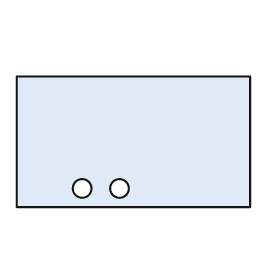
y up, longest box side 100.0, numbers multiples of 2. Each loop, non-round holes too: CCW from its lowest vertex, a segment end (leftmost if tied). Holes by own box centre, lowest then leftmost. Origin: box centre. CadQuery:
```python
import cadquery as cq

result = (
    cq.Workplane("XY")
    .moveTo(-50.0, -28.0)
    .lineTo(50.0, -28.0)
    .lineTo(50.0, 28.0)
    .lineTo(-50.0, 28.0)
    .close()
    .moveTo(-22.0, -20.0)
    .circle(4.0)
    .moveTo(-6.0, -20.0)
    .circle(4.0)
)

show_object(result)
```